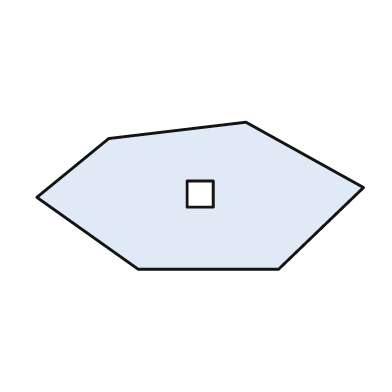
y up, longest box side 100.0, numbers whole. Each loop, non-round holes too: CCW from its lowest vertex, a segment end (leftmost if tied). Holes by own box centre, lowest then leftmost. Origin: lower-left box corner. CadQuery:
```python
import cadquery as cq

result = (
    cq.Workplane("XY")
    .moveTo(31.0, 0.0)
    .lineTo(74.0, 0.0)
    .lineTo(100.0, 25.0)
    .lineTo(64.0, 45.0)
    .lineTo(22.0, 40.0)
    .lineTo(0.0, 22.0)
    .close()
    .moveTo(46.0, 19.0)
    .lineTo(54.0, 19.0)
    .lineTo(54.0, 27.0)
    .lineTo(46.0, 27.0)
    .close()
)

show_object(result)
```